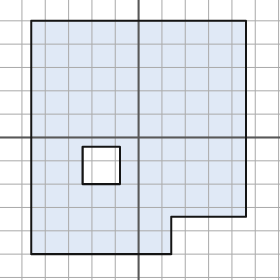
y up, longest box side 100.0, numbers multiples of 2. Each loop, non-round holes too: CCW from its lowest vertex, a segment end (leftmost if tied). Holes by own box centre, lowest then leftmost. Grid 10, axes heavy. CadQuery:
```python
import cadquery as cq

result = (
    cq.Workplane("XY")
    .moveTo(-46.0, -50.0)
    .lineTo(14.0, -50.0)
    .lineTo(14.0, -34.0)
    .lineTo(46.0, -34.0)
    .lineTo(46.0, 50.0)
    .lineTo(-46.0, 50.0)
    .close()
    .moveTo(-24.0, -20.0)
    .lineTo(-8.0, -20.0)
    .lineTo(-8.0, -4.0)
    .lineTo(-24.0, -4.0)
    .close()
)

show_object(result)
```